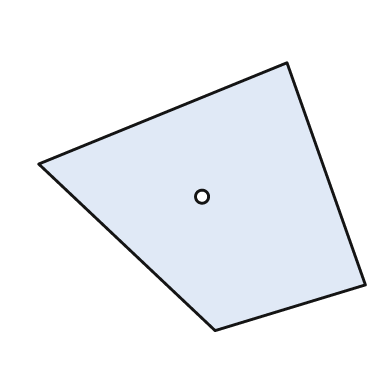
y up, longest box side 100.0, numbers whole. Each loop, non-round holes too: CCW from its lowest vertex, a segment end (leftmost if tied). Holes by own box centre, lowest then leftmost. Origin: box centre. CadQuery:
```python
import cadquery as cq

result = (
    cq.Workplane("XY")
    .moveTo(4.0, -41.0)
    .lineTo(50.0, -27.0)
    .lineTo(26.0, 41.0)
    .lineTo(-50.0, 10.0)
    .close()
    .moveTo(0.0, 0.0)
    .circle(2.0)
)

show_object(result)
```